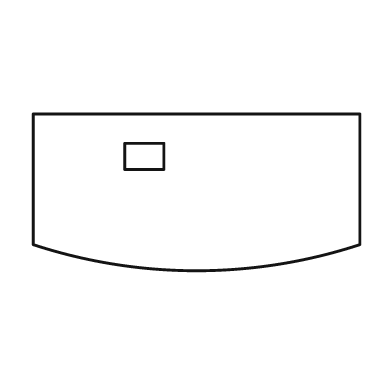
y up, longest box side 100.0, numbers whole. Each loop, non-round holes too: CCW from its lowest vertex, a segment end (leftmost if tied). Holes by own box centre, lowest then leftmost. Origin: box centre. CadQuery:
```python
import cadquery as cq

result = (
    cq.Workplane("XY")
    .moveTo(-50.0, -16.0)
    .threePointArc((0.0, -24.0), (50.0, -16.0))
    .lineTo(50.0, 24.0)
    .lineTo(-50.0, 24.0)
    .close()
    .moveTo(-22.0, 7.0)
    .lineTo(-10.0, 7.0)
    .lineTo(-10.0, 15.0)
    .lineTo(-22.0, 15.0)
    .close()
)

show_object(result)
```